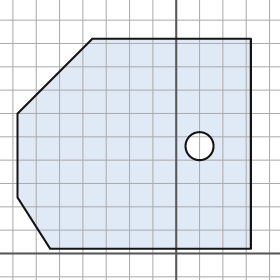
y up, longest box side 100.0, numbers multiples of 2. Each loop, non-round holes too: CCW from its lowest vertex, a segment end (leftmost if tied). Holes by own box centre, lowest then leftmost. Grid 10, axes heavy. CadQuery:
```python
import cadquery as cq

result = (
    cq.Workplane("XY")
    .moveTo(-54.0, 2.0)
    .lineTo(32.0, 2.0)
    .lineTo(32.0, 92.0)
    .lineTo(-36.0, 92.0)
    .lineTo(-68.0, 60.0)
    .lineTo(-68.0, 24.0)
    .close()
    .moveTo(10.0, 46.0)
    .circle(6.0)
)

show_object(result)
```